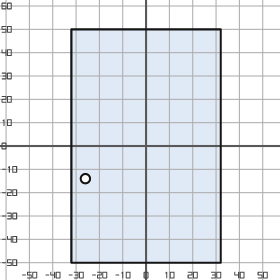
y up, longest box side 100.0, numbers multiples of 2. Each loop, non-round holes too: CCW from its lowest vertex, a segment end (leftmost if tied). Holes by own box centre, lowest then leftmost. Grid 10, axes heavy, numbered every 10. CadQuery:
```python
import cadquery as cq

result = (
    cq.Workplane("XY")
    .moveTo(-32.0, -50.0)
    .lineTo(32.0, -50.0)
    .lineTo(32.0, 50.0)
    .lineTo(-32.0, 50.0)
    .close()
    .moveTo(-26.0, -14.0)
    .circle(2.0)
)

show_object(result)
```